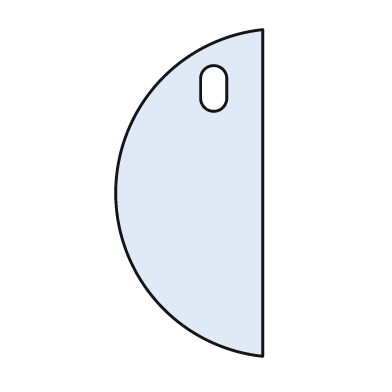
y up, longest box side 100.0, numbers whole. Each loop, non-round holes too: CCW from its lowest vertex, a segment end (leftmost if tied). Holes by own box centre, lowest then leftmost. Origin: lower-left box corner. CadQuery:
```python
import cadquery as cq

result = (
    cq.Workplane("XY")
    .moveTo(45.0, 0.0)
    .lineTo(45.0, 100.0)
    .threePointArc((0.0, 50.0), (45.0, 0.0))
    .close()
    .moveTo(26.0, 79.0)
    .threePointArc((30.0, 75.0), (34.0, 79.0))
    .lineTo(34.0, 85.0)
    .threePointArc((30.0, 89.0), (26.0, 85.0))
    .close()
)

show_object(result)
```